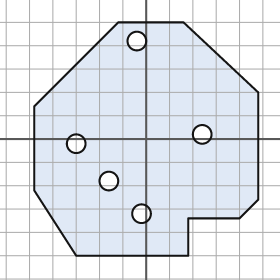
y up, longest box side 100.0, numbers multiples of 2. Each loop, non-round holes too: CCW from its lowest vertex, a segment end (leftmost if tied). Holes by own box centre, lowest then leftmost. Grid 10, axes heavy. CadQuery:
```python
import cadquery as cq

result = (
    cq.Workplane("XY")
    .moveTo(-30.0, -50.0)
    .lineTo(18.0, -50.0)
    .lineTo(18.0, -34.0)
    .lineTo(40.0, -34.0)
    .lineTo(48.0, -26.0)
    .lineTo(48.0, 20.0)
    .lineTo(16.0, 50.0)
    .lineTo(-12.0, 50.0)
    .lineTo(-48.0, 14.0)
    .lineTo(-48.0, -22.0)
    .close()
    .moveTo(-2.0, -32.0)
    .circle(4.0)
    .moveTo(-16.0, -18.0)
    .circle(4.0)
    .moveTo(-30.0, -2.0)
    .circle(4.0)
    .moveTo(24.0, 2.0)
    .circle(4.0)
    .moveTo(-4.0, 42.0)
    .circle(4.0)
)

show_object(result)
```